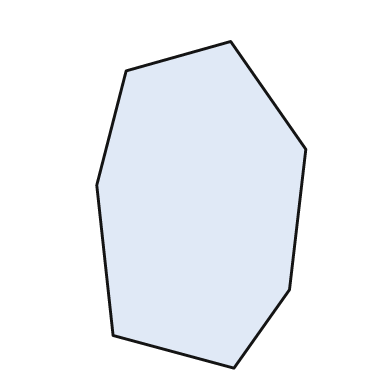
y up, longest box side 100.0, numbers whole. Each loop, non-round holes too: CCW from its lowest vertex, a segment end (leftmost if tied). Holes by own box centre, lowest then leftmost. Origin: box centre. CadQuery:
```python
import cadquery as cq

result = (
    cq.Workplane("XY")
    .moveTo(10.0, -50.0)
    .lineTo(27.0, -26.0)
    .lineTo(32.0, 17.0)
    .lineTo(9.0, 50.0)
    .lineTo(-23.0, 41.0)
    .lineTo(-32.0, 6.0)
    .lineTo(-27.0, -40.0)
    .close()
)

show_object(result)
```